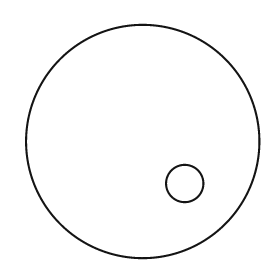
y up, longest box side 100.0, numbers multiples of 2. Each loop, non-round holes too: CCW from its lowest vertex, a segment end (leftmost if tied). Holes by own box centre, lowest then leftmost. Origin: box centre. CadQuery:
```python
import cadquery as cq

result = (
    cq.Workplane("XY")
    .moveTo(0.0, 0.0)
    .circle(50.0)
    .moveTo(18.0, -18.0)
    .circle(8.0)
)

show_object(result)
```